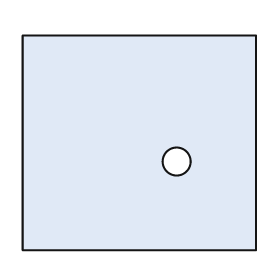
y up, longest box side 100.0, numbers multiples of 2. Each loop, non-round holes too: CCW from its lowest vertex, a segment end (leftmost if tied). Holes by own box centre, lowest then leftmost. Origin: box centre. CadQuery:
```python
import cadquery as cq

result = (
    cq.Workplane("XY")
    .moveTo(-50.0, -46.0)
    .lineTo(50.0, -46.0)
    .lineTo(50.0, 46.0)
    .lineTo(-50.0, 46.0)
    .close()
    .moveTo(16.0, -8.0)
    .circle(6.0)
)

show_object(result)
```